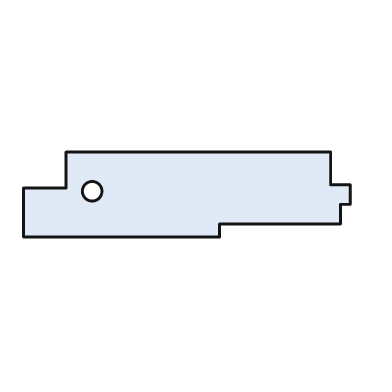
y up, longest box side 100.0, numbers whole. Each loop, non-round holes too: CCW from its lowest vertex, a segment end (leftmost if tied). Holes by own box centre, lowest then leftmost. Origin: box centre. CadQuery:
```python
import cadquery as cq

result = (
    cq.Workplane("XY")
    .moveTo(-50.0, -13.0)
    .lineTo(10.0, -13.0)
    .lineTo(10.0, -9.0)
    .lineTo(47.0, -9.0)
    .lineTo(47.0, -3.0)
    .lineTo(50.0, -3.0)
    .lineTo(50.0, 3.0)
    .lineTo(44.0, 3.0)
    .lineTo(44.0, 13.0)
    .lineTo(-37.0, 13.0)
    .lineTo(-37.0, 2.0)
    .lineTo(-50.0, 2.0)
    .close()
    .moveTo(-29.0, 1.0)
    .circle(3.0)
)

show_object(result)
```